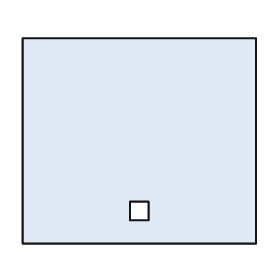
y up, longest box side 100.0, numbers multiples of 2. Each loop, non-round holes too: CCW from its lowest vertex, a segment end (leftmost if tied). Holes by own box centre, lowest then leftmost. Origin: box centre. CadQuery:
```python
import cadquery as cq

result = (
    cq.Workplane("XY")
    .moveTo(-50.0, -44.0)
    .lineTo(50.0, -44.0)
    .lineTo(50.0, 44.0)
    .lineTo(-50.0, 44.0)
    .close()
    .moveTo(-4.0, -34.0)
    .lineTo(4.0, -34.0)
    .lineTo(4.0, -26.0)
    .lineTo(-4.0, -26.0)
    .close()
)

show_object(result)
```